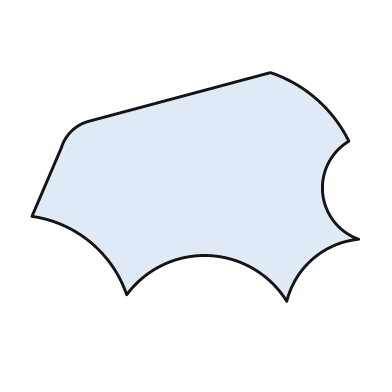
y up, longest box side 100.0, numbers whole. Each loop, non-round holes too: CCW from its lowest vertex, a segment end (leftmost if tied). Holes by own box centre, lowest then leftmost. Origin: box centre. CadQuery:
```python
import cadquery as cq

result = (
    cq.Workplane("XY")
    .moveTo(28.0, -35.0)
    .threePointArc((36.0, -22.0), (50.0, -16.0))
    .threePointArc((39.0, -2.0), (47.0, 14.0))
    .threePointArc((37.0, 27.0), (23.0, 35.0))
    .lineTo(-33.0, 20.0)
    .threePointArc((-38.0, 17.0), (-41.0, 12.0))
    .lineTo(-50.0, -9.0)
    .threePointArc((-32.0, -17.0), (-21.0, -33.0))
    .threePointArc((4.0, -21.0), (28.0, -35.0))
    .close()
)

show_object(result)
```